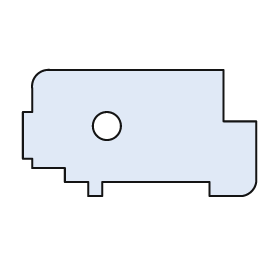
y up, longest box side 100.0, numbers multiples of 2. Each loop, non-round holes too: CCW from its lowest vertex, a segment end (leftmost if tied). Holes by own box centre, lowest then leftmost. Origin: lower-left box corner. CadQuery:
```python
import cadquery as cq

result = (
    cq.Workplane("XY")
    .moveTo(28.0, 0.0)
    .lineTo(34.0, 0.0)
    .lineTo(34.0, 6.0)
    .lineTo(80.0, 6.0)
    .lineTo(80.0, 0.0)
    .lineTo(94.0, 0.0)
    .threePointArc((98.0, 2.0), (100.0, 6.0))
    .lineTo(100.0, 32.0)
    .lineTo(86.0, 32.0)
    .lineTo(86.0, 54.0)
    .lineTo(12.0, 54.0)
    .threePointArc((6.0, 52.0), (4.0, 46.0))
    .lineTo(4.0, 36.0)
    .lineTo(0.0, 36.0)
    .lineTo(0.0, 16.0)
    .lineTo(4.0, 16.0)
    .lineTo(4.0, 12.0)
    .lineTo(18.0, 12.0)
    .lineTo(18.0, 6.0)
    .lineTo(28.0, 6.0)
    .close()
    .moveTo(36.0, 30.0)
    .circle(6.0)
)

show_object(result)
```